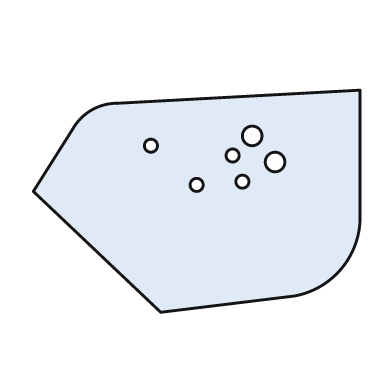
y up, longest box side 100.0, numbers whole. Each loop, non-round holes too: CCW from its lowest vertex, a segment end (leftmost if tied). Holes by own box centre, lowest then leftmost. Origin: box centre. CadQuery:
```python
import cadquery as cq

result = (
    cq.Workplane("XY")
    .moveTo(-11.0, -34.0)
    .lineTo(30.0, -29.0)
    .threePointArc((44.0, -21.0), (50.0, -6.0))
    .lineTo(50.0, 34.0)
    .lineTo(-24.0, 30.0)
    .threePointArc((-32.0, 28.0), (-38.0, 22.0))
    .lineTo(-50.0, 3.0)
    .close()
    .moveTo(0.0, 5.0)
    .circle(2.0)
    .moveTo(14.0, 6.0)
    .circle(2.0)
    .moveTo(24.0, 12.0)
    .circle(3.0)
    .moveTo(11.0, 14.0)
    .circle(2.0)
    .moveTo(-14.0, 17.0)
    .circle(2.0)
    .moveTo(17.0, 20.0)
    .circle(3.0)
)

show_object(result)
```